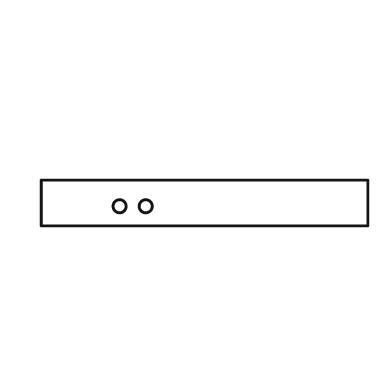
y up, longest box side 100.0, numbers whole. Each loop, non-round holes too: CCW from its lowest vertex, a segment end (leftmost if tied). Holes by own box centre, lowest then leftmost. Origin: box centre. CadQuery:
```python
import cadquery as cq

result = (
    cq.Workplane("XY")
    .moveTo(-50.0, -7.0)
    .lineTo(50.0, -7.0)
    .lineTo(50.0, 7.0)
    .lineTo(-50.0, 7.0)
    .close()
    .moveTo(-26.0, -1.0)
    .circle(2.0)
    .moveTo(-18.0, -1.0)
    .circle(2.0)
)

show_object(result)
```